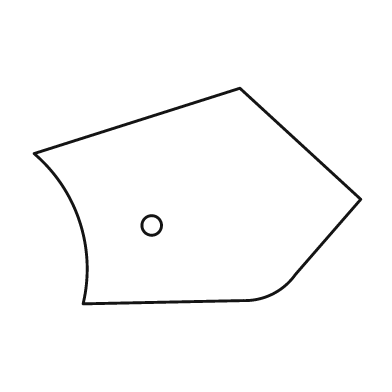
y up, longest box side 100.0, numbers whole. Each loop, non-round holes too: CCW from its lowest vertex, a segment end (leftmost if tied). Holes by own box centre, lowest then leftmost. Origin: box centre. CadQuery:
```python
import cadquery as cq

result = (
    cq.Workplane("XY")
    .moveTo(-35.0, -33.0)
    .lineTo(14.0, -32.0)
    .threePointArc((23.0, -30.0), (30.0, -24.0))
    .lineTo(50.0, -1.0)
    .lineTo(13.0, 33.0)
    .lineTo(-50.0, 13.0)
    .threePointArc((-36.0, -8.0), (-35.0, -33.0))
    .close()
    .moveTo(-14.0, -9.0)
    .circle(3.0)
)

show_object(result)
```